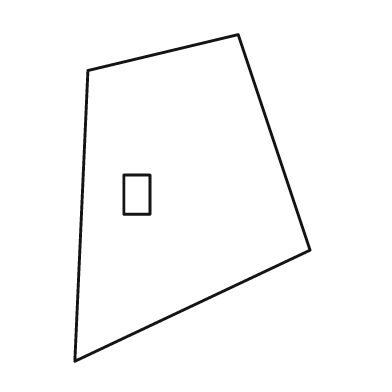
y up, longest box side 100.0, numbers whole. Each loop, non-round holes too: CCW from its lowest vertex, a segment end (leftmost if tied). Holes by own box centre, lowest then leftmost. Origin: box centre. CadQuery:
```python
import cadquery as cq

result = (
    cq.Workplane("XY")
    .moveTo(-36.0, -50.0)
    .lineTo(36.0, -16.0)
    .lineTo(14.0, 50.0)
    .lineTo(-32.0, 39.0)
    .close()
    .moveTo(-21.0, -5.0)
    .lineTo(-13.0, -5.0)
    .lineTo(-13.0, 7.0)
    .lineTo(-21.0, 7.0)
    .close()
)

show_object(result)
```